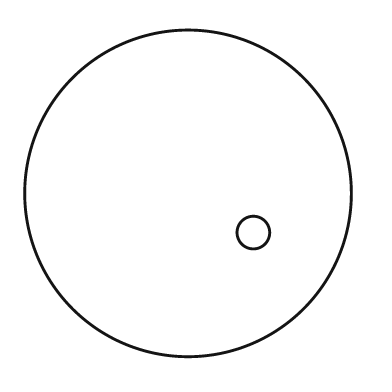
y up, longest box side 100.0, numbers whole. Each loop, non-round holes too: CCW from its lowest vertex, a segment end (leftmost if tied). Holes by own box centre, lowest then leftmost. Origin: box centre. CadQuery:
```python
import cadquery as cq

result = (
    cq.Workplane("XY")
    .moveTo(0.0, 0.0)
    .circle(50.0)
    .moveTo(20.0, -12.0)
    .circle(5.0)
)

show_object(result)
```